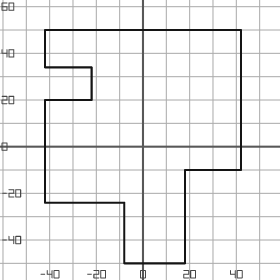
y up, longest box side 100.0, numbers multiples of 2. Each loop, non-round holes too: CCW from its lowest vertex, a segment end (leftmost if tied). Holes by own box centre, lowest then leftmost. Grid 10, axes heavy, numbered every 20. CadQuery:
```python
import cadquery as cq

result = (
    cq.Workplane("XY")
    .moveTo(-8.0, -50.0)
    .lineTo(18.0, -50.0)
    .lineTo(18.0, -10.0)
    .lineTo(42.0, -10.0)
    .lineTo(42.0, 50.0)
    .lineTo(-42.0, 50.0)
    .lineTo(-42.0, 34.0)
    .lineTo(-22.0, 34.0)
    .lineTo(-22.0, 20.0)
    .lineTo(-42.0, 20.0)
    .lineTo(-42.0, -24.0)
    .lineTo(-8.0, -24.0)
    .close()
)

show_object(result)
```